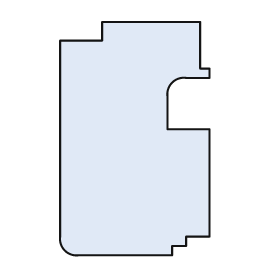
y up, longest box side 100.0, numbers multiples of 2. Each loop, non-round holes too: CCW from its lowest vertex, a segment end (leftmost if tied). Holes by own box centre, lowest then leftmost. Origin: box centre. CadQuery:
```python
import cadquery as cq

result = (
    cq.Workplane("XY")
    .moveTo(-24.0, -50.0)
    .lineTo(16.0, -50.0)
    .lineTo(16.0, -46.0)
    .lineTo(22.0, -46.0)
    .lineTo(22.0, -42.0)
    .lineTo(32.0, -42.0)
    .lineTo(32.0, 4.0)
    .lineTo(14.0, 4.0)
    .lineTo(14.0, 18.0)
    .threePointArc((16.0, 24.0), (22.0, 26.0))
    .lineTo(32.0, 26.0)
    .lineTo(32.0, 30.0)
    .lineTo(28.0, 30.0)
    .lineTo(28.0, 50.0)
    .lineTo(-14.0, 50.0)
    .lineTo(-14.0, 42.0)
    .lineTo(-32.0, 42.0)
    .lineTo(-32.0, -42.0)
    .threePointArc((-30.0, -48.0), (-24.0, -50.0))
    .close()
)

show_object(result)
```